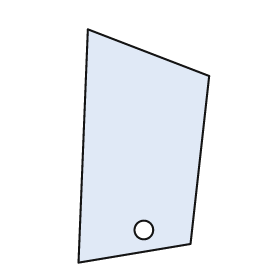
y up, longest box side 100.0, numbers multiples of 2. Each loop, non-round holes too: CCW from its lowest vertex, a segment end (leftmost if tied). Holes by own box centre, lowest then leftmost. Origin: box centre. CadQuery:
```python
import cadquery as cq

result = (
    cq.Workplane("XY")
    .moveTo(-28.0, -50.0)
    .lineTo(20.0, -42.0)
    .lineTo(28.0, 30.0)
    .lineTo(-24.0, 50.0)
    .close()
    .moveTo(0.0, -36.0)
    .circle(4.0)
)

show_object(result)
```